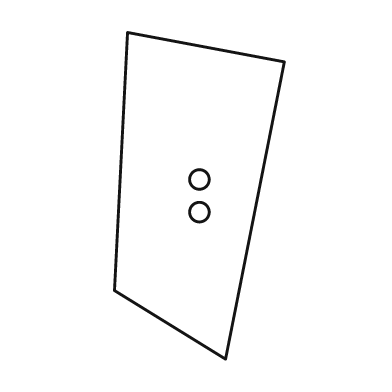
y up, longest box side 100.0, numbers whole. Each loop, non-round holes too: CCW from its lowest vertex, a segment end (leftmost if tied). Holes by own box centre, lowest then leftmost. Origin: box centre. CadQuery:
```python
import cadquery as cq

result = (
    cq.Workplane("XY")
    .moveTo(8.0, -50.0)
    .lineTo(26.0, 41.0)
    .lineTo(-22.0, 50.0)
    .lineTo(-26.0, -29.0)
    .close()
    .moveTo(0.0, -5.0)
    .circle(3.0)
    .moveTo(0.0, 5.0)
    .circle(3.0)
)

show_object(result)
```